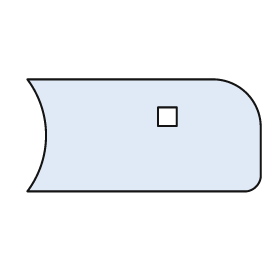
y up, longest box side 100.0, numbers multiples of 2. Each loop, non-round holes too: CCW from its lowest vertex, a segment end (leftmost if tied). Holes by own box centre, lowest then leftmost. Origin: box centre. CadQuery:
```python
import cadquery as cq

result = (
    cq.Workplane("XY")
    .moveTo(-50.0, -24.0)
    .lineTo(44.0, -24.0)
    .threePointArc((48.0, -22.0), (50.0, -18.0))
    .lineTo(50.0, 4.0)
    .threePointArc((44.0, 18.0), (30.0, 24.0))
    .lineTo(-50.0, 24.0)
    .threePointArc((-42.0, 0.0), (-50.0, -24.0))
    .close()
    .moveTo(6.0, 4.0)
    .lineTo(14.0, 4.0)
    .lineTo(14.0, 12.0)
    .lineTo(6.0, 12.0)
    .close()
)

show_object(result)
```